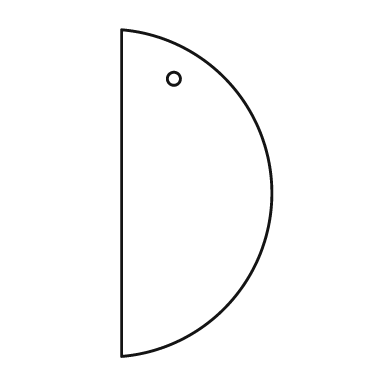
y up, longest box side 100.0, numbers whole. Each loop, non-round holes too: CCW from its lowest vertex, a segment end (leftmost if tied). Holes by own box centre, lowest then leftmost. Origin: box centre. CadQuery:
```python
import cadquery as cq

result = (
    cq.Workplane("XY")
    .moveTo(-23.0, -50.0)
    .threePointArc((23.0, 0.0), (-23.0, 50.0))
    .close()
    .moveTo(-7.0, 35.0)
    .circle(2.0)
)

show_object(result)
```